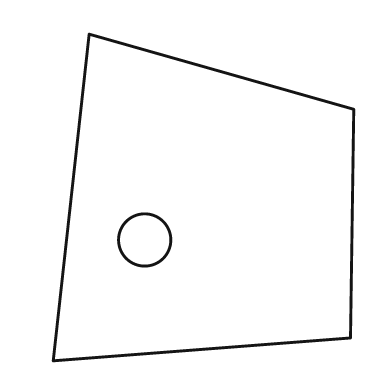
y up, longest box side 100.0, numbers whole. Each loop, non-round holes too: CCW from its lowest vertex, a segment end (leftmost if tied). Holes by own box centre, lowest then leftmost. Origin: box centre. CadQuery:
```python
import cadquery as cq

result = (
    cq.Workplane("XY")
    .moveTo(-46.0, -50.0)
    .lineTo(45.0, -43.0)
    .lineTo(46.0, 27.0)
    .lineTo(-35.0, 50.0)
    .close()
    .moveTo(-18.0, -13.0)
    .circle(8.0)
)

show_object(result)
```